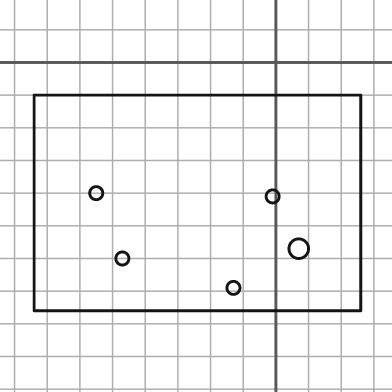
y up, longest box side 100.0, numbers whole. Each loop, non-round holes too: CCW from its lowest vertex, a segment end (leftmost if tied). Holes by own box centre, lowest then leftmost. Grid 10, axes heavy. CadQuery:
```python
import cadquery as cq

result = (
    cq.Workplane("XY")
    .moveTo(-74.0, -76.0)
    .lineTo(26.0, -76.0)
    .lineTo(26.0, -10.0)
    .lineTo(-74.0, -10.0)
    .close()
    .moveTo(-13.0, -69.0)
    .circle(2.0)
    .moveTo(-47.0, -60.0)
    .circle(2.0)
    .moveTo(7.0, -57.0)
    .circle(3.0)
    .moveTo(-1.0, -41.0)
    .circle(2.0)
    .moveTo(-55.0, -40.0)
    .circle(2.0)
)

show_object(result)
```